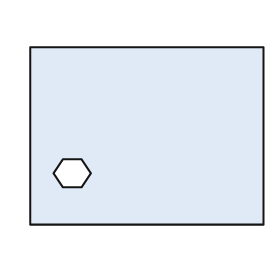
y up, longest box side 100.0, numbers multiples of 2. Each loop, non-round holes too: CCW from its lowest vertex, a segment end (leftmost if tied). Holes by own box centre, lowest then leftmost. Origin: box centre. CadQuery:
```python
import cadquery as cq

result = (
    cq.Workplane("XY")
    .moveTo(-50.0, -38.0)
    .lineTo(50.0, -38.0)
    .lineTo(50.0, 38.0)
    .lineTo(-50.0, 38.0)
    .close()
    .moveTo(-36.0, -22.0)
    .lineTo(-28.0, -22.0)
    .lineTo(-24.0, -16.0)
    .lineTo(-28.0, -10.0)
    .lineTo(-36.0, -10.0)
    .lineTo(-40.0, -16.0)
    .close()
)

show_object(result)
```